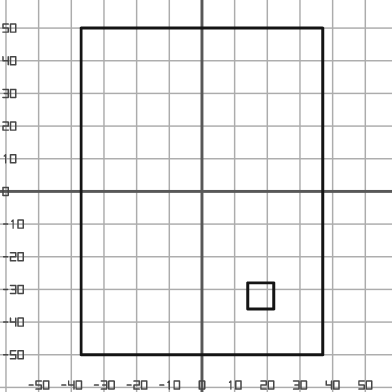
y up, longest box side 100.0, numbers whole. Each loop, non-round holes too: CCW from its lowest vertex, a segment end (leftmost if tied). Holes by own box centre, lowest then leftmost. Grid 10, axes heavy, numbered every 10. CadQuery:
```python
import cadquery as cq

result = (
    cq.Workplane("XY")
    .moveTo(-37.0, -50.0)
    .lineTo(37.0, -50.0)
    .lineTo(37.0, 50.0)
    .lineTo(-37.0, 50.0)
    .close()
    .moveTo(14.0, -36.0)
    .lineTo(22.0, -36.0)
    .lineTo(22.0, -28.0)
    .lineTo(14.0, -28.0)
    .close()
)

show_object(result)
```